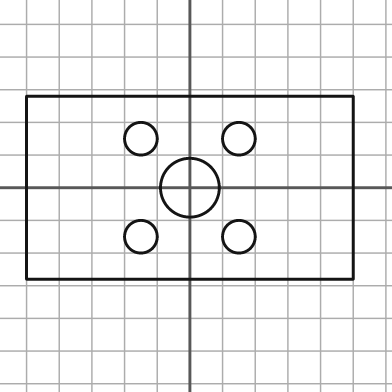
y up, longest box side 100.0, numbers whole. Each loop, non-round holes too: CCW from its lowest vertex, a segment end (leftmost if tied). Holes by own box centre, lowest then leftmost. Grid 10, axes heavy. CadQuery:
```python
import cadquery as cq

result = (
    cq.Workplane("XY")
    .moveTo(-50.0, -28.0)
    .lineTo(50.0, -28.0)
    .lineTo(50.0, 28.0)
    .lineTo(-50.0, 28.0)
    .close()
    .moveTo(-15.0, -15.0)
    .circle(5.0)
    .moveTo(15.0, -15.0)
    .circle(5.0)
    .moveTo(0.0, 0.0)
    .circle(9.0)
    .moveTo(-15.0, 15.0)
    .circle(5.0)
    .moveTo(15.0, 15.0)
    .circle(5.0)
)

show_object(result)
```